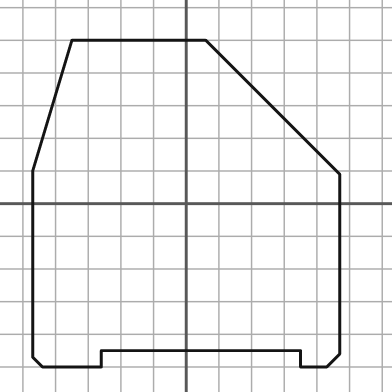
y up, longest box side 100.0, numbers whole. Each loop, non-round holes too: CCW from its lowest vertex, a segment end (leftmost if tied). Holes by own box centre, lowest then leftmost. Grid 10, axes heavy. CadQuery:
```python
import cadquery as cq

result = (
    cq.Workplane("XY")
    .moveTo(-44.0, -50.0)
    .lineTo(-26.0, -50.0)
    .lineTo(-26.0, -45.0)
    .lineTo(35.0, -45.0)
    .lineTo(35.0, -50.0)
    .lineTo(43.0, -50.0)
    .lineTo(47.0, -46.0)
    .lineTo(47.0, 9.0)
    .lineTo(6.0, 50.0)
    .lineTo(-35.0, 50.0)
    .lineTo(-47.0, 10.0)
    .lineTo(-47.0, -47.0)
    .close()
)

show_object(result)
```